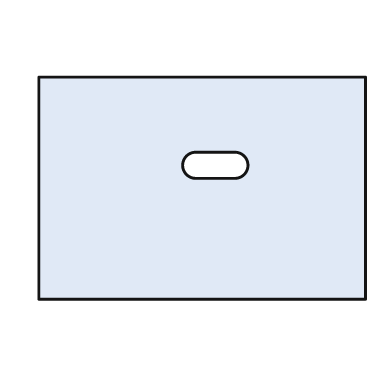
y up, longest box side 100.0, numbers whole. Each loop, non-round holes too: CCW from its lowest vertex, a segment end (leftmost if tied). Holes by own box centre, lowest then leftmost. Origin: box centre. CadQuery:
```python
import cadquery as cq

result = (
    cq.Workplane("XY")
    .moveTo(-50.0, -34.0)
    .lineTo(50.0, -34.0)
    .lineTo(50.0, 34.0)
    .lineTo(-50.0, 34.0)
    .close()
    .moveTo(-2.0, 3.0)
    .lineTo(10.0, 3.0)
    .threePointArc((14.0, 7.0), (10.0, 11.0))
    .lineTo(-2.0, 11.0)
    .threePointArc((-6.0, 7.0), (-2.0, 3.0))
    .close()
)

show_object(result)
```